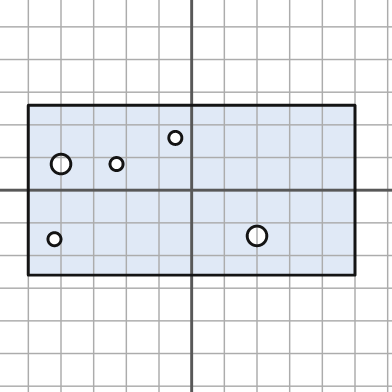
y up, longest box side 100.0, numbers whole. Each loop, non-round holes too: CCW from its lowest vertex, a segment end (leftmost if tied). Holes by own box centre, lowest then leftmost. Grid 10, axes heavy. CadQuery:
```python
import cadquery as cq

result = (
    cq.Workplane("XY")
    .moveTo(-50.0, -26.0)
    .lineTo(50.0, -26.0)
    .lineTo(50.0, 26.0)
    .lineTo(-50.0, 26.0)
    .close()
    .moveTo(-42.0, -15.0)
    .circle(2.0)
    .moveTo(20.0, -14.0)
    .circle(3.0)
    .moveTo(-40.0, 8.0)
    .circle(3.0)
    .moveTo(-23.0, 8.0)
    .circle(2.0)
    .moveTo(-5.0, 16.0)
    .circle(2.0)
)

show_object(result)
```